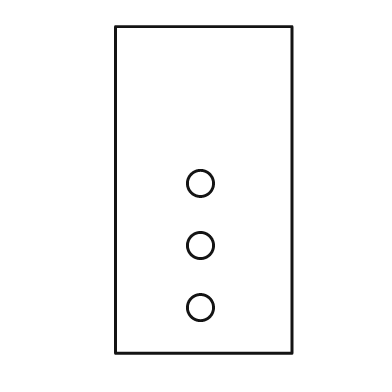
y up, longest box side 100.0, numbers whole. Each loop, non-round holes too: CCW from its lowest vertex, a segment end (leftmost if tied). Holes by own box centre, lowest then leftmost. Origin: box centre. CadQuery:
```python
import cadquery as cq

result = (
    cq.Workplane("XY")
    .moveTo(-27.0, -50.0)
    .lineTo(27.0, -50.0)
    .lineTo(27.0, 50.0)
    .lineTo(-27.0, 50.0)
    .close()
    .moveTo(-1.0, -36.0)
    .circle(4.0)
    .moveTo(-1.0, -17.0)
    .circle(4.0)
    .moveTo(-1.0, 2.0)
    .circle(4.0)
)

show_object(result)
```